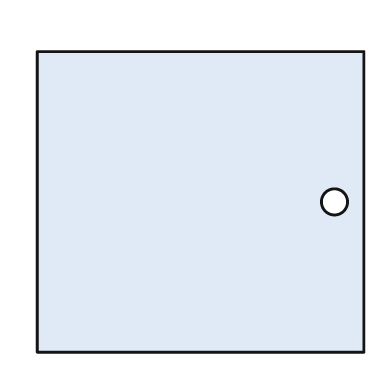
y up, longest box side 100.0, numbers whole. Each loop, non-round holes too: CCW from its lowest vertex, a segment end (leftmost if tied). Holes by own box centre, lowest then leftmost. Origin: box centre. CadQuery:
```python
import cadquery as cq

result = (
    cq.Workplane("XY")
    .moveTo(-50.0, -46.0)
    .lineTo(50.0, -46.0)
    .lineTo(50.0, 46.0)
    .lineTo(-50.0, 46.0)
    .close()
    .moveTo(41.0, 0.0)
    .circle(4.0)
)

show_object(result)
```